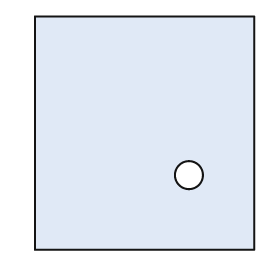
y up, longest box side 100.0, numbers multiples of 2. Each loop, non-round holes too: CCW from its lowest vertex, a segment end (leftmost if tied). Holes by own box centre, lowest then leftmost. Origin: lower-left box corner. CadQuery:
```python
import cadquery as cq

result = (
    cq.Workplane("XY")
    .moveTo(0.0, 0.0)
    .lineTo(94.0, 0.0)
    .lineTo(94.0, 100.0)
    .lineTo(0.0, 100.0)
    .close()
    .moveTo(66.0, 32.0)
    .circle(6.0)
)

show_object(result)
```